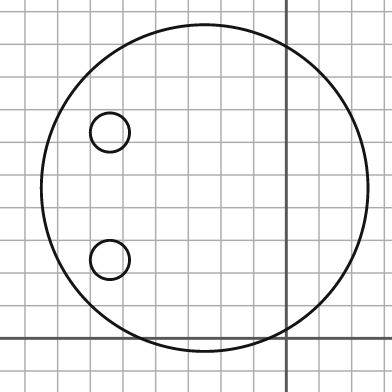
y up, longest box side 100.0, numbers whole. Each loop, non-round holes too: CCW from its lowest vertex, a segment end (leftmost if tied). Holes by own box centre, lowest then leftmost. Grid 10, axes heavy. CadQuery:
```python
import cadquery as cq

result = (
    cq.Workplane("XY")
    .moveTo(-25.0, 46.0)
    .circle(50.0)
    .moveTo(-54.0, 24.0)
    .circle(6.0)
    .moveTo(-54.0, 63.0)
    .circle(6.0)
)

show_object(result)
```